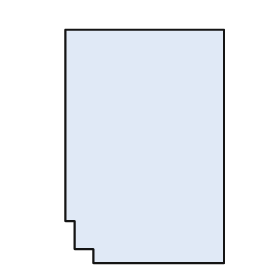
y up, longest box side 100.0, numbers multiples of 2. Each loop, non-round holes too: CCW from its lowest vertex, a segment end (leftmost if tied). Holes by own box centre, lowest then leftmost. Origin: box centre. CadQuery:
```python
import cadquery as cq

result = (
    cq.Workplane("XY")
    .moveTo(-22.0, -50.0)
    .lineTo(34.0, -50.0)
    .lineTo(34.0, 50.0)
    .lineTo(-34.0, 50.0)
    .lineTo(-34.0, -32.0)
    .lineTo(-30.0, -32.0)
    .lineTo(-30.0, -44.0)
    .lineTo(-22.0, -44.0)
    .close()
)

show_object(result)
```